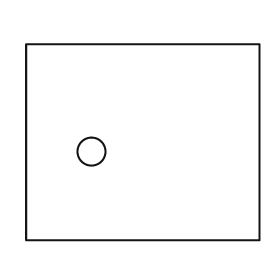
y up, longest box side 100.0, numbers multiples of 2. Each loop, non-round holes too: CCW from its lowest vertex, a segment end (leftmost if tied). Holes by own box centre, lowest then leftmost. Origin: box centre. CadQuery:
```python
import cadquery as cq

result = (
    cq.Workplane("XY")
    .moveTo(-50.0, -42.0)
    .lineTo(50.0, -42.0)
    .lineTo(50.0, 42.0)
    .lineTo(-50.0, 42.0)
    .close()
    .moveTo(-22.0, -4.0)
    .circle(6.0)
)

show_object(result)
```